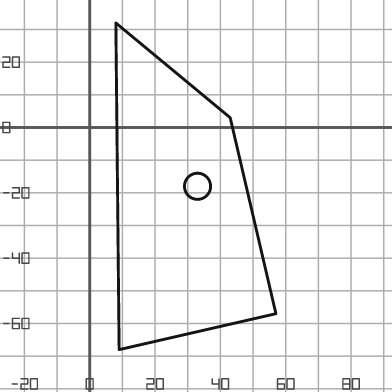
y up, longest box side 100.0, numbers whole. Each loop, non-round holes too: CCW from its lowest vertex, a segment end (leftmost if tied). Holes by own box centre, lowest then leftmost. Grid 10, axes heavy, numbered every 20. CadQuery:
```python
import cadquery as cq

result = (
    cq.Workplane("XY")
    .moveTo(9.0, -68.0)
    .lineTo(57.0, -57.0)
    .lineTo(43.0, 3.0)
    .lineTo(8.0, 32.0)
    .close()
    .moveTo(33.0, -18.0)
    .circle(4.0)
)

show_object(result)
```